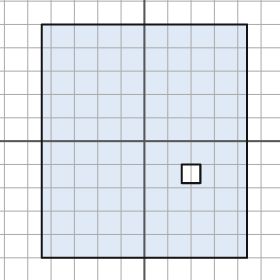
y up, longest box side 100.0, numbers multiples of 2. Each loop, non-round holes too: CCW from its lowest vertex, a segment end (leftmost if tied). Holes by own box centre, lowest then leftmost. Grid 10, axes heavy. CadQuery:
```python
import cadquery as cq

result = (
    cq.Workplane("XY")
    .moveTo(-44.0, -50.0)
    .lineTo(44.0, -50.0)
    .lineTo(44.0, 50.0)
    .lineTo(-44.0, 50.0)
    .close()
    .moveTo(16.0, -18.0)
    .lineTo(24.0, -18.0)
    .lineTo(24.0, -10.0)
    .lineTo(16.0, -10.0)
    .close()
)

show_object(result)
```